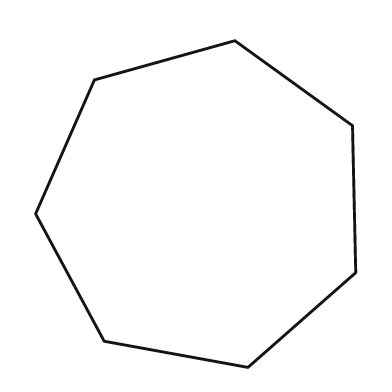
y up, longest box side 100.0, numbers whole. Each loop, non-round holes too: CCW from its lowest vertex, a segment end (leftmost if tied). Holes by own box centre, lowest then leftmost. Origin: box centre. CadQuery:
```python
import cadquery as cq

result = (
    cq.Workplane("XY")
    .moveTo(16.0, -50.0)
    .lineTo(49.0, -21.0)
    .lineTo(48.0, 24.0)
    .lineTo(12.0, 50.0)
    .lineTo(-31.0, 38.0)
    .lineTo(-49.0, -3.0)
    .lineTo(-28.0, -42.0)
    .close()
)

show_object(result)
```